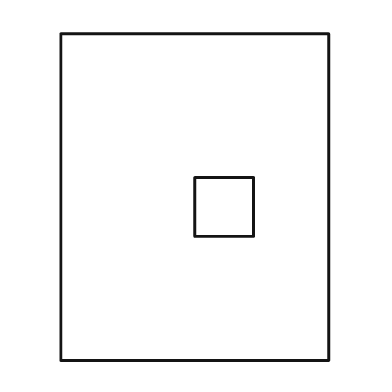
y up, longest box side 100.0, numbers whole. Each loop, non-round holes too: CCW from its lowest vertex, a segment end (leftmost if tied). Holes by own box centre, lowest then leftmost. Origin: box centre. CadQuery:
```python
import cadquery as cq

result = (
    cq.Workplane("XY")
    .moveTo(-41.0, -50.0)
    .lineTo(41.0, -50.0)
    .lineTo(41.0, 50.0)
    .lineTo(-41.0, 50.0)
    .close()
    .moveTo(0.0, -12.0)
    .lineTo(18.0, -12.0)
    .lineTo(18.0, 6.0)
    .lineTo(0.0, 6.0)
    .close()
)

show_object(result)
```